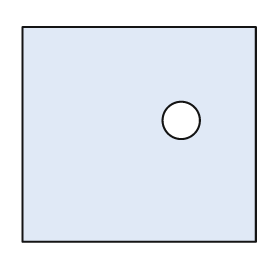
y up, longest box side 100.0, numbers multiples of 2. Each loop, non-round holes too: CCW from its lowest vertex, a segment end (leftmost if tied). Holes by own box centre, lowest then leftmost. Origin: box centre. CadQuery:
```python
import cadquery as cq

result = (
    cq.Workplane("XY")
    .moveTo(-50.0, -46.0)
    .lineTo(50.0, -46.0)
    .lineTo(50.0, 46.0)
    .lineTo(-50.0, 46.0)
    .close()
    .moveTo(18.0, 6.0)
    .circle(8.0)
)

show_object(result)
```